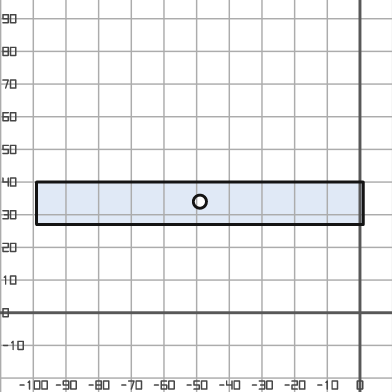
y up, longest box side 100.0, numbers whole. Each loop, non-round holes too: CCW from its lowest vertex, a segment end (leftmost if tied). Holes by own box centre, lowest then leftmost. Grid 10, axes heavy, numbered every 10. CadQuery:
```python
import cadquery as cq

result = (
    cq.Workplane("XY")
    .moveTo(-99.0, 27.0)
    .lineTo(1.0, 27.0)
    .lineTo(1.0, 40.0)
    .lineTo(-99.0, 40.0)
    .close()
    .moveTo(-49.0, 34.0)
    .circle(2.0)
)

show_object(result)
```